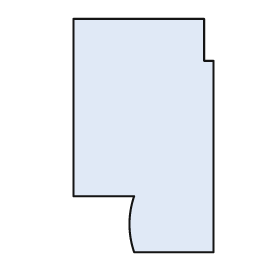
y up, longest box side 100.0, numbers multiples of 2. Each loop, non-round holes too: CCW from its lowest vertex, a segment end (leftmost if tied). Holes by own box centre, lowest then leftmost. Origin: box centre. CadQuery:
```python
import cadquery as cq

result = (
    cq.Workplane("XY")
    .moveTo(-4.0, -50.0)
    .lineTo(30.0, -50.0)
    .lineTo(30.0, 32.0)
    .lineTo(26.0, 32.0)
    .lineTo(26.0, 50.0)
    .lineTo(-30.0, 50.0)
    .lineTo(-30.0, -26.0)
    .lineTo(-4.0, -26.0)
    .threePointArc((-6.0, -38.0), (-4.0, -50.0))
    .close()
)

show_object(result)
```